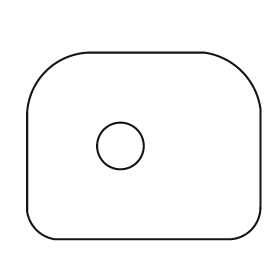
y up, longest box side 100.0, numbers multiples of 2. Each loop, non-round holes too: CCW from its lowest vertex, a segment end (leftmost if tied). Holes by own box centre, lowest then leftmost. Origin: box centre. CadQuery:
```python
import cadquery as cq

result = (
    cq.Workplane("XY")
    .moveTo(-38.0, -40.0)
    .lineTo(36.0, -40.0)
    .threePointArc((46.0, -36.0), (50.0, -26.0))
    .lineTo(50.0, 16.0)
    .threePointArc((42.0, 32.0), (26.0, 40.0))
    .lineTo(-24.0, 40.0)
    .threePointArc((-42.0, 32.0), (-50.0, 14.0))
    .lineTo(-50.0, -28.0)
    .threePointArc((-46.0, -36.0), (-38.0, -40.0))
    .close()
    .moveTo(-10.0, 0.0)
    .circle(10.0)
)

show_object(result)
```